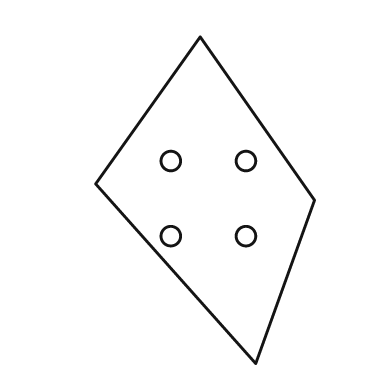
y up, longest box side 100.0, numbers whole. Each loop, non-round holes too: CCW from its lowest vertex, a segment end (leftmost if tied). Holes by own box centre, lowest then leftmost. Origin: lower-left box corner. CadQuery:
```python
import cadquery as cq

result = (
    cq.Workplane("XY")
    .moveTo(49.0, 0.0)
    .lineTo(67.0, 50.0)
    .lineTo(32.0, 100.0)
    .lineTo(0.0, 55.0)
    .close()
    .moveTo(23.0, 39.0)
    .circle(3.0)
    .moveTo(46.0, 39.0)
    .circle(3.0)
    .moveTo(23.0, 62.0)
    .circle(3.0)
    .moveTo(46.0, 62.0)
    .circle(3.0)
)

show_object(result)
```